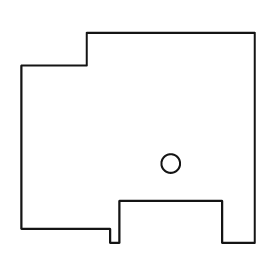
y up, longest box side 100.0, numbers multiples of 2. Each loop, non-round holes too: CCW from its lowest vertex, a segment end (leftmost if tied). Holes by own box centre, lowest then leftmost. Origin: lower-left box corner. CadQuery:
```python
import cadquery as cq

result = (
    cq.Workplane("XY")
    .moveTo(38.0, 0.0)
    .lineTo(42.0, 0.0)
    .lineTo(42.0, 18.0)
    .lineTo(86.0, 18.0)
    .lineTo(86.0, 0.0)
    .lineTo(100.0, 0.0)
    .lineTo(100.0, 90.0)
    .lineTo(28.0, 90.0)
    .lineTo(28.0, 76.0)
    .lineTo(0.0, 76.0)
    .lineTo(0.0, 6.0)
    .lineTo(38.0, 6.0)
    .close()
    .moveTo(64.0, 34.0)
    .circle(4.0)
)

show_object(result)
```